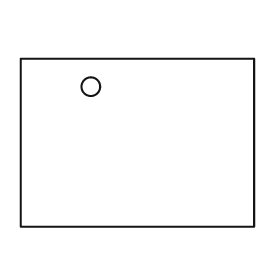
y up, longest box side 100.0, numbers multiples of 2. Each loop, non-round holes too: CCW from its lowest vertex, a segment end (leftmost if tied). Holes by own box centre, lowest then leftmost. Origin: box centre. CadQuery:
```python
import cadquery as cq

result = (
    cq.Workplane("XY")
    .moveTo(-50.0, -36.0)
    .lineTo(50.0, -36.0)
    .lineTo(50.0, 36.0)
    .lineTo(-50.0, 36.0)
    .close()
    .moveTo(-20.0, 24.0)
    .circle(4.0)
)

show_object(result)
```